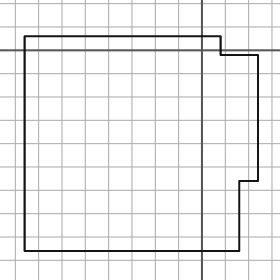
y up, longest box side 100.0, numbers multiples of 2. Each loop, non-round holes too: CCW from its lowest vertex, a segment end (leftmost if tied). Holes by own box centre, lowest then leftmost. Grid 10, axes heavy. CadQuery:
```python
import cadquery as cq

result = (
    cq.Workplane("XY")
    .moveTo(-76.0, -86.0)
    .lineTo(16.0, -86.0)
    .lineTo(16.0, -56.0)
    .lineTo(24.0, -56.0)
    .lineTo(24.0, -2.0)
    .lineTo(8.0, -2.0)
    .lineTo(8.0, 6.0)
    .lineTo(-76.0, 6.0)
    .close()
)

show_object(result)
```